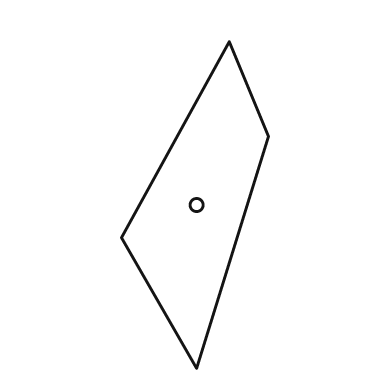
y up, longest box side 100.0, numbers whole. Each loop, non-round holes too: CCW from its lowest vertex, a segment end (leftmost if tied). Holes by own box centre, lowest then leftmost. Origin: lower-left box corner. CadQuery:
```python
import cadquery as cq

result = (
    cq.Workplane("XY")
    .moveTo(23.0, 0.0)
    .lineTo(45.0, 71.0)
    .lineTo(33.0, 100.0)
    .lineTo(0.0, 40.0)
    .close()
    .moveTo(23.0, 50.0)
    .circle(2.0)
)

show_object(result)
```